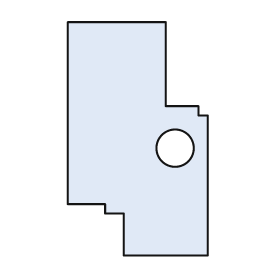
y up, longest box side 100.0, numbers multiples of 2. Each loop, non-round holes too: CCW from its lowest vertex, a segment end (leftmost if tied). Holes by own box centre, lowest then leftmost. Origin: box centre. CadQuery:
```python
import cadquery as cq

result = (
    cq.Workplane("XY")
    .moveTo(-6.0, -50.0)
    .lineTo(30.0, -50.0)
    .lineTo(30.0, 10.0)
    .lineTo(26.0, 10.0)
    .lineTo(26.0, 14.0)
    .lineTo(12.0, 14.0)
    .lineTo(12.0, 50.0)
    .lineTo(-30.0, 50.0)
    .lineTo(-30.0, -28.0)
    .lineTo(-14.0, -28.0)
    .lineTo(-14.0, -32.0)
    .lineTo(-6.0, -32.0)
    .close()
    .moveTo(16.0, -4.0)
    .circle(8.0)
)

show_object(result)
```